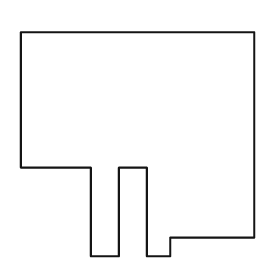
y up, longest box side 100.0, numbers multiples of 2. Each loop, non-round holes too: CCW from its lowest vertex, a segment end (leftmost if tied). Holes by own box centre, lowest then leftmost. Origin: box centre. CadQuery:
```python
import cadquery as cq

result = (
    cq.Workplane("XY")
    .moveTo(-20.0, -48.0)
    .lineTo(-8.0, -48.0)
    .lineTo(-8.0, -10.0)
    .lineTo(4.0, -10.0)
    .lineTo(4.0, -48.0)
    .lineTo(14.0, -48.0)
    .lineTo(14.0, -40.0)
    .lineTo(50.0, -40.0)
    .lineTo(50.0, 48.0)
    .lineTo(-50.0, 48.0)
    .lineTo(-50.0, -10.0)
    .lineTo(-20.0, -10.0)
    .close()
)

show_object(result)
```